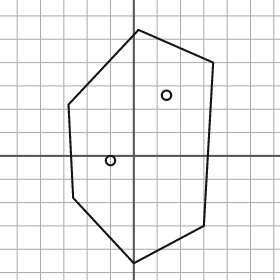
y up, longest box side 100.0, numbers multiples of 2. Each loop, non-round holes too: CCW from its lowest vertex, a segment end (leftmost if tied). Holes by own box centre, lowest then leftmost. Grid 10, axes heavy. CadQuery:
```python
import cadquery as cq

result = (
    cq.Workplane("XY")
    .moveTo(0.0, -46.0)
    .lineTo(30.0, -30.0)
    .lineTo(34.0, 40.0)
    .lineTo(2.0, 54.0)
    .lineTo(-28.0, 22.0)
    .lineTo(-26.0, -18.0)
    .close()
    .moveTo(-10.0, -2.0)
    .circle(2.0)
    .moveTo(14.0, 26.0)
    .circle(2.0)
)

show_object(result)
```